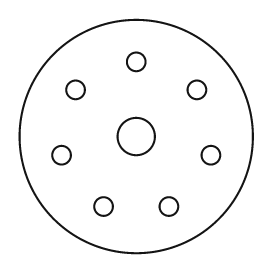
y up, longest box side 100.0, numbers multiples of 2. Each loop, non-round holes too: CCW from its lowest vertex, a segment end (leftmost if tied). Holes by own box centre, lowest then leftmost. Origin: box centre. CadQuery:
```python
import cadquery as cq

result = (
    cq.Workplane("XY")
    .moveTo(0.0, 0.0)
    .circle(50.0)
    .moveTo(-14.0, -30.0)
    .circle(4.0)
    .moveTo(14.0, -30.0)
    .circle(4.0)
    .moveTo(-32.0, -8.0)
    .circle(4.0)
    .moveTo(32.0, -8.0)
    .circle(4.0)
    .moveTo(0.0, 0.0)
    .circle(8.0)
    .moveTo(-26.0, 20.0)
    .circle(4.0)
    .moveTo(26.0, 20.0)
    .circle(4.0)
    .moveTo(0.0, 32.0)
    .circle(4.0)
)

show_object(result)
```